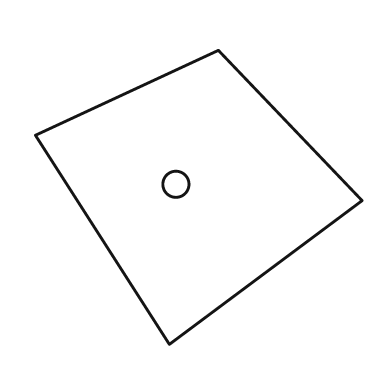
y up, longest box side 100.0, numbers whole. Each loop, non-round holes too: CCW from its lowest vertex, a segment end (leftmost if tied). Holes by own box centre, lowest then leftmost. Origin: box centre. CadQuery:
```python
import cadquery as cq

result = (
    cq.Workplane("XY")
    .moveTo(-9.0, -45.0)
    .lineTo(50.0, -1.0)
    .lineTo(6.0, 45.0)
    .lineTo(-50.0, 19.0)
    .close()
    .moveTo(-7.0, 4.0)
    .circle(4.0)
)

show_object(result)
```